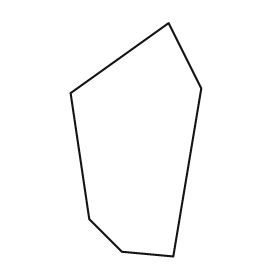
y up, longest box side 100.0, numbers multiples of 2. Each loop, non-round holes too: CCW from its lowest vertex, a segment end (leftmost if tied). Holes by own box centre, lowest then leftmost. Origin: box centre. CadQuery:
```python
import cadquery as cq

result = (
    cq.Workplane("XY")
    .moveTo(16.0, -50.0)
    .lineTo(28.0, 22.0)
    .lineTo(14.0, 50.0)
    .lineTo(-28.0, 20.0)
    .lineTo(-20.0, -34.0)
    .lineTo(-6.0, -48.0)
    .close()
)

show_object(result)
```